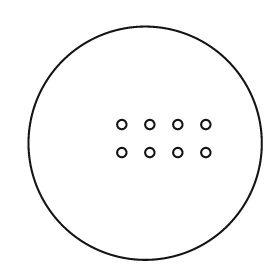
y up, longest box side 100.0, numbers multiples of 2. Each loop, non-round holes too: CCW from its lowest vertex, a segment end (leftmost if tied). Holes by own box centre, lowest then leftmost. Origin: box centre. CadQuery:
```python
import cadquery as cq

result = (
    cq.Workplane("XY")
    .moveTo(0.0, 0.0)
    .circle(50.0)
    .moveTo(-10.0, -4.0)
    .circle(2.0)
    .moveTo(2.0, -4.0)
    .circle(2.0)
    .moveTo(14.0, -4.0)
    .circle(2.0)
    .moveTo(26.0, -4.0)
    .circle(2.0)
    .moveTo(-10.0, 8.0)
    .circle(2.0)
    .moveTo(2.0, 8.0)
    .circle(2.0)
    .moveTo(14.0, 8.0)
    .circle(2.0)
    .moveTo(26.0, 8.0)
    .circle(2.0)
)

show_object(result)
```